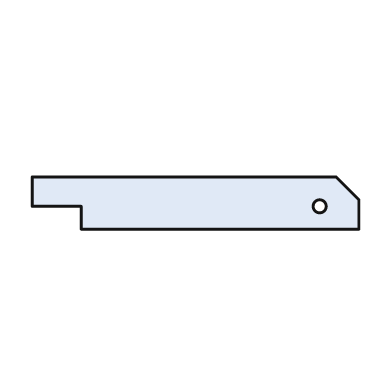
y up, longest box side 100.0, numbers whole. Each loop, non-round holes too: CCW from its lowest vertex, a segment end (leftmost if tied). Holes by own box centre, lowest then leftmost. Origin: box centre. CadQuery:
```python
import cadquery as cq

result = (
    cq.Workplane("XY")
    .moveTo(-35.0, -8.0)
    .lineTo(50.0, -8.0)
    .lineTo(50.0, 1.0)
    .lineTo(43.0, 8.0)
    .lineTo(-50.0, 8.0)
    .lineTo(-50.0, -1.0)
    .lineTo(-35.0, -1.0)
    .close()
    .moveTo(38.0, -1.0)
    .circle(2.0)
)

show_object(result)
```